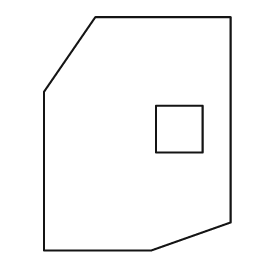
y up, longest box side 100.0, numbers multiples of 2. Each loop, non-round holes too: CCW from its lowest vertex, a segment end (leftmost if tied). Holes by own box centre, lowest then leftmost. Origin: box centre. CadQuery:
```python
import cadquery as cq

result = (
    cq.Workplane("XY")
    .moveTo(-40.0, -50.0)
    .lineTo(6.0, -50.0)
    .lineTo(40.0, -38.0)
    .lineTo(40.0, 50.0)
    .lineTo(-18.0, 50.0)
    .lineTo(-40.0, 18.0)
    .close()
    .moveTo(8.0, -8.0)
    .lineTo(28.0, -8.0)
    .lineTo(28.0, 12.0)
    .lineTo(8.0, 12.0)
    .close()
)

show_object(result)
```